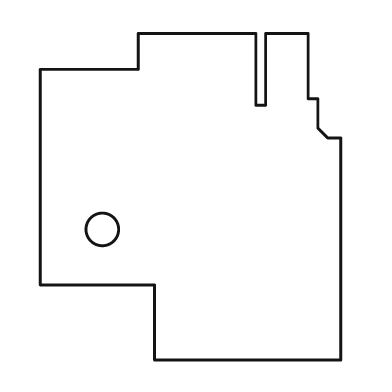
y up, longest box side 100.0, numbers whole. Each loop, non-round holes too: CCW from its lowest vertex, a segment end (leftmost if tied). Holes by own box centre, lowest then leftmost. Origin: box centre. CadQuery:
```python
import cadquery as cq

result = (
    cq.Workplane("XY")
    .moveTo(-11.0, -50.0)
    .lineTo(46.0, -50.0)
    .lineTo(46.0, 18.0)
    .lineTo(42.0, 18.0)
    .lineTo(39.0, 21.0)
    .lineTo(39.0, 30.0)
    .lineTo(36.0, 30.0)
    .lineTo(36.0, 50.0)
    .lineTo(23.0, 50.0)
    .lineTo(23.0, 28.0)
    .lineTo(20.0, 28.0)
    .lineTo(20.0, 50.0)
    .lineTo(-16.0, 50.0)
    .lineTo(-16.0, 39.0)
    .lineTo(-46.0, 39.0)
    .lineTo(-46.0, -27.0)
    .lineTo(-11.0, -27.0)
    .close()
    .moveTo(-27.0, -10.0)
    .circle(5.0)
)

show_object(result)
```